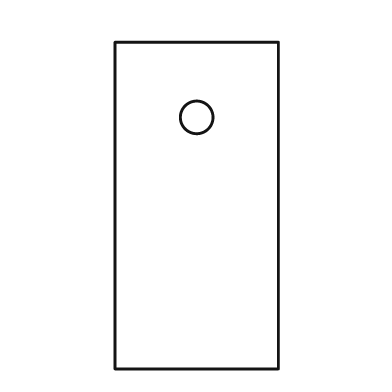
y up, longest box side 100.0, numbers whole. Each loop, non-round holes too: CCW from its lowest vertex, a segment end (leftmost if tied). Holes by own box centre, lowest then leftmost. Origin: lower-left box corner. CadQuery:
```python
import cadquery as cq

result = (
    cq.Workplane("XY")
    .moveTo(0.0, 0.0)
    .lineTo(50.0, 0.0)
    .lineTo(50.0, 100.0)
    .lineTo(0.0, 100.0)
    .close()
    .moveTo(25.0, 77.0)
    .circle(5.0)
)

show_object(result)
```